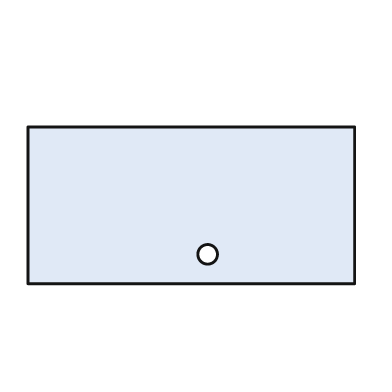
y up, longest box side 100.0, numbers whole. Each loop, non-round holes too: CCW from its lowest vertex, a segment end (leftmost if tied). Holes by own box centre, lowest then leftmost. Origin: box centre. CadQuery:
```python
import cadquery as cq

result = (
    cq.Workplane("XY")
    .moveTo(-50.0, -24.0)
    .lineTo(50.0, -24.0)
    .lineTo(50.0, 24.0)
    .lineTo(-50.0, 24.0)
    .close()
    .moveTo(5.0, -15.0)
    .circle(3.0)
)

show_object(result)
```